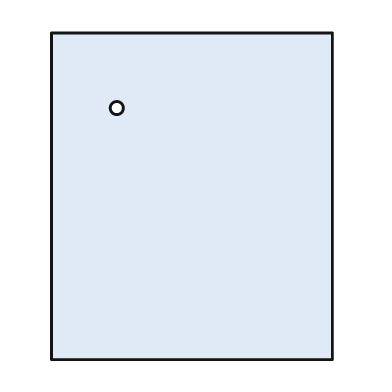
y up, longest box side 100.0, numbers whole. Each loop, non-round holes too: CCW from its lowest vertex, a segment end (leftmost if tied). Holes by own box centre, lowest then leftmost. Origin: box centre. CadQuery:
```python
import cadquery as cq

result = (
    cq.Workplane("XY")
    .moveTo(-43.0, -50.0)
    .lineTo(43.0, -50.0)
    .lineTo(43.0, 50.0)
    .lineTo(-43.0, 50.0)
    .close()
    .moveTo(-23.0, 27.0)
    .circle(2.0)
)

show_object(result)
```